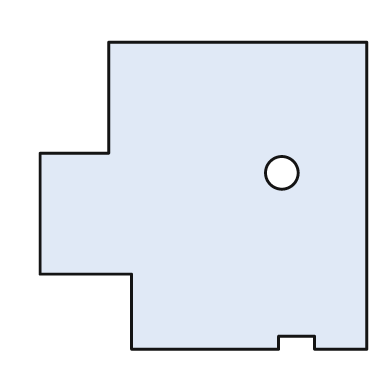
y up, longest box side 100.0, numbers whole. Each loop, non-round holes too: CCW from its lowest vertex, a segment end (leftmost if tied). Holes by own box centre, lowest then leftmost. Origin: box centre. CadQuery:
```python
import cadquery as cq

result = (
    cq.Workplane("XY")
    .moveTo(-22.0, -47.0)
    .lineTo(23.0, -47.0)
    .lineTo(23.0, -43.0)
    .lineTo(34.0, -43.0)
    .lineTo(34.0, -47.0)
    .lineTo(50.0, -47.0)
    .lineTo(50.0, 47.0)
    .lineTo(-29.0, 47.0)
    .lineTo(-29.0, 13.0)
    .lineTo(-50.0, 13.0)
    .lineTo(-50.0, -24.0)
    .lineTo(-22.0, -24.0)
    .close()
    .moveTo(24.0, 7.0)
    .circle(5.0)
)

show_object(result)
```